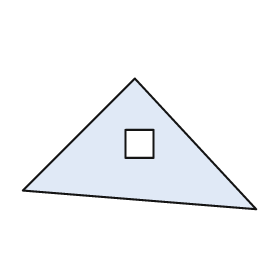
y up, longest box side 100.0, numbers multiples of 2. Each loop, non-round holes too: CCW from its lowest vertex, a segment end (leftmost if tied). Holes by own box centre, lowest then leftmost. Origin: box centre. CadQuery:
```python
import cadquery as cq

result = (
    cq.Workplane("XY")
    .moveTo(50.0, -28.0)
    .lineTo(-2.0, 28.0)
    .lineTo(-50.0, -20.0)
    .close()
    .moveTo(-6.0, -6.0)
    .lineTo(6.0, -6.0)
    .lineTo(6.0, 6.0)
    .lineTo(-6.0, 6.0)
    .close()
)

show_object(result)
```